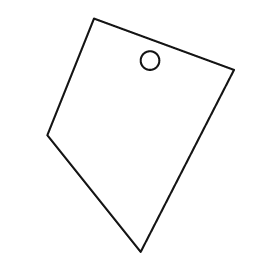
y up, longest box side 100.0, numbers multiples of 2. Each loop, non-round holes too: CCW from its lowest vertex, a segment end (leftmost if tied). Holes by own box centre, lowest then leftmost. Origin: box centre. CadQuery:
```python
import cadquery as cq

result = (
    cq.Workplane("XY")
    .moveTo(0.0, -50.0)
    .lineTo(40.0, 28.0)
    .lineTo(-20.0, 50.0)
    .lineTo(-40.0, 0.0)
    .close()
    .moveTo(4.0, 32.0)
    .circle(4.0)
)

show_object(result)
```